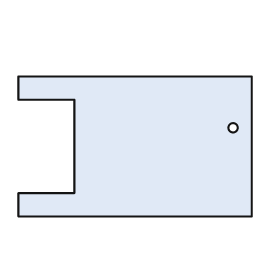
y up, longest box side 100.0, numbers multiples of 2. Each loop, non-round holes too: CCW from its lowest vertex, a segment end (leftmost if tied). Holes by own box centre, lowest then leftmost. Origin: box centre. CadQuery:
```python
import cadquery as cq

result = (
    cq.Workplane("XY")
    .moveTo(-50.0, -30.0)
    .lineTo(50.0, -30.0)
    .lineTo(50.0, 30.0)
    .lineTo(-50.0, 30.0)
    .lineTo(-50.0, 20.0)
    .lineTo(-26.0, 20.0)
    .lineTo(-26.0, -20.0)
    .lineTo(-50.0, -20.0)
    .close()
    .moveTo(42.0, 8.0)
    .circle(2.0)
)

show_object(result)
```